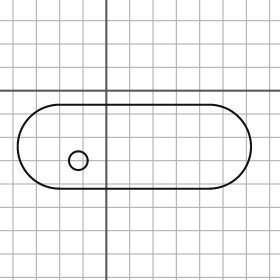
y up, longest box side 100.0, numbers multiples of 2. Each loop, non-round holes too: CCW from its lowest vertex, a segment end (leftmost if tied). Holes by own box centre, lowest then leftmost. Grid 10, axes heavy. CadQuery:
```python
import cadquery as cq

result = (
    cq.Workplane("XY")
    .moveTo(-20.0, -42.0)
    .lineTo(44.0, -42.0)
    .threePointArc((62.0, -24.0), (44.0, -6.0))
    .lineTo(-20.0, -6.0)
    .threePointArc((-38.0, -24.0), (-20.0, -42.0))
    .close()
    .moveTo(-12.0, -30.0)
    .circle(4.0)
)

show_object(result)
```